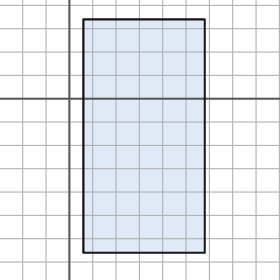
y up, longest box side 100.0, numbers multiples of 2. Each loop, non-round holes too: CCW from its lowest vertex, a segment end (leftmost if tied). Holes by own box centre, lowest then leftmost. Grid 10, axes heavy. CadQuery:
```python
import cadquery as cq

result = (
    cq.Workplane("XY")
    .moveTo(6.0, -66.0)
    .lineTo(58.0, -66.0)
    .lineTo(58.0, 34.0)
    .lineTo(6.0, 34.0)
    .close()
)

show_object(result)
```